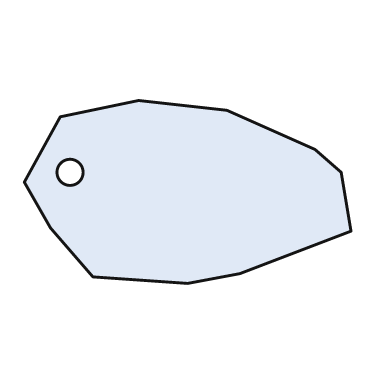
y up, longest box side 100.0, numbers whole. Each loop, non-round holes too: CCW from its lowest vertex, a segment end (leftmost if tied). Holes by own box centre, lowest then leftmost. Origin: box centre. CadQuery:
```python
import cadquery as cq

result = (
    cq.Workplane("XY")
    .moveTo(0.0, -28.0)
    .lineTo(16.0, -25.0)
    .lineTo(50.0, -12.0)
    .lineTo(47.0, 6.0)
    .lineTo(39.0, 13.0)
    .lineTo(12.0, 25.0)
    .lineTo(-15.0, 28.0)
    .lineTo(-39.0, 23.0)
    .lineTo(-50.0, 3.0)
    .lineTo(-42.0, -11.0)
    .lineTo(-29.0, -26.0)
    .close()
    .moveTo(-36.0, 6.0)
    .circle(4.0)
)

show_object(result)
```